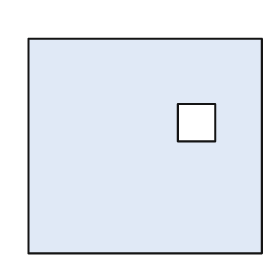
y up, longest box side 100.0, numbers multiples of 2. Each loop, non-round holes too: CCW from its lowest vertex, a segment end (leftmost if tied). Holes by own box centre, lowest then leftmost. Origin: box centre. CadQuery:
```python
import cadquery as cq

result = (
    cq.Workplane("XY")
    .moveTo(-50.0, -46.0)
    .lineTo(50.0, -46.0)
    .lineTo(50.0, 46.0)
    .lineTo(-50.0, 46.0)
    .close()
    .moveTo(14.0, 2.0)
    .lineTo(30.0, 2.0)
    .lineTo(30.0, 18.0)
    .lineTo(14.0, 18.0)
    .close()
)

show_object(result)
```